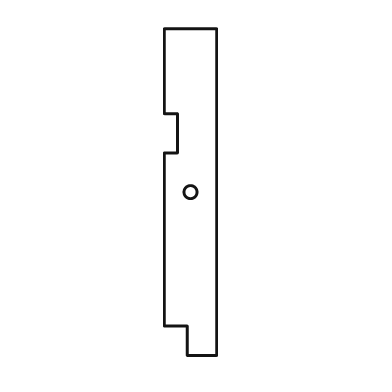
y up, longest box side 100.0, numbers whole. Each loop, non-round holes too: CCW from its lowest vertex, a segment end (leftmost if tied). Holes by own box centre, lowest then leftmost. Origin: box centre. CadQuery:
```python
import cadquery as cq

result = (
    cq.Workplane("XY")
    .moveTo(-1.0, -50.0)
    .lineTo(8.0, -50.0)
    .lineTo(8.0, 50.0)
    .lineTo(-8.0, 50.0)
    .lineTo(-8.0, 24.0)
    .lineTo(-4.0, 24.0)
    .lineTo(-4.0, 12.0)
    .lineTo(-8.0, 12.0)
    .lineTo(-8.0, -41.0)
    .lineTo(-1.0, -41.0)
    .close()
    .moveTo(0.0, 0.0)
    .circle(2.0)
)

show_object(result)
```